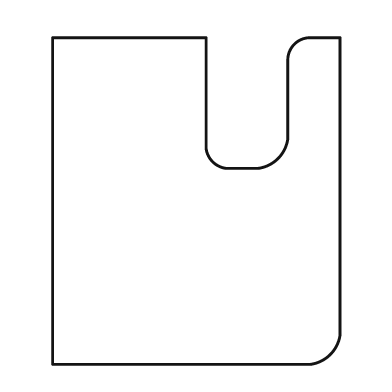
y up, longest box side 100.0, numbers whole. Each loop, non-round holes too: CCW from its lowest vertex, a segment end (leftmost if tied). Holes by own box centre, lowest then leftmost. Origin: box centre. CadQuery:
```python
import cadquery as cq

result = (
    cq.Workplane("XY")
    .moveTo(-44.0, -50.0)
    .lineTo(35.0, -50.0)
    .threePointArc((41.0, -47.0), (44.0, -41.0))
    .lineTo(44.0, 50.0)
    .lineTo(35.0, 50.0)
    .threePointArc((30.0, 48.0), (28.0, 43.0))
    .lineTo(28.0, 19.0)
    .threePointArc((25.0, 13.0), (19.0, 10.0))
    .lineTo(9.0, 10.0)
    .threePointArc((5.0, 12.0), (3.0, 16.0))
    .lineTo(3.0, 50.0)
    .lineTo(-44.0, 50.0)
    .close()
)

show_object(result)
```